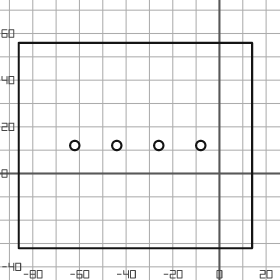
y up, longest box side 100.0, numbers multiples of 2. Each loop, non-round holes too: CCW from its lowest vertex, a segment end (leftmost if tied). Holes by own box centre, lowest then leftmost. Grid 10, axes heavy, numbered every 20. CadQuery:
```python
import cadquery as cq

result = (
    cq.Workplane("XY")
    .moveTo(-86.0, -32.0)
    .lineTo(14.0, -32.0)
    .lineTo(14.0, 56.0)
    .lineTo(-86.0, 56.0)
    .close()
    .moveTo(-62.0, 12.0)
    .circle(2.0)
    .moveTo(-44.0, 12.0)
    .circle(2.0)
    .moveTo(-26.0, 12.0)
    .circle(2.0)
    .moveTo(-8.0, 12.0)
    .circle(2.0)
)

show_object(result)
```